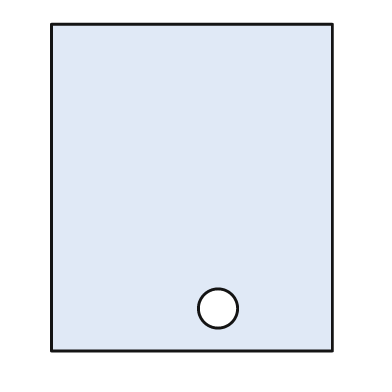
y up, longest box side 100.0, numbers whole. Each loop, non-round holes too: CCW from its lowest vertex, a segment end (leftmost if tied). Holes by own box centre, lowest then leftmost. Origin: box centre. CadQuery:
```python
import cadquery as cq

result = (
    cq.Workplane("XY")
    .moveTo(-43.0, -50.0)
    .lineTo(43.0, -50.0)
    .lineTo(43.0, 50.0)
    .lineTo(-43.0, 50.0)
    .close()
    .moveTo(8.0, -37.0)
    .circle(6.0)
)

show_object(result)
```